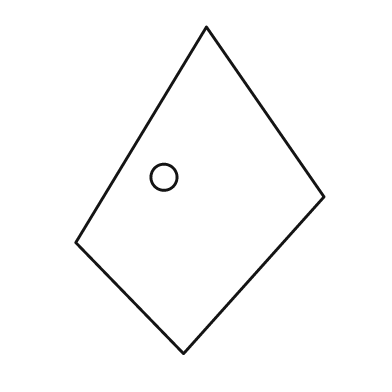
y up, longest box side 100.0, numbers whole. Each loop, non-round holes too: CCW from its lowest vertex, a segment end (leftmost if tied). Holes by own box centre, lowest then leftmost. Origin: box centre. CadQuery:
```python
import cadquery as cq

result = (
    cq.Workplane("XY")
    .moveTo(-5.0, -50.0)
    .lineTo(38.0, -2.0)
    .lineTo(2.0, 50.0)
    .lineTo(-38.0, -16.0)
    .close()
    .moveTo(-11.0, 4.0)
    .circle(4.0)
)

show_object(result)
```